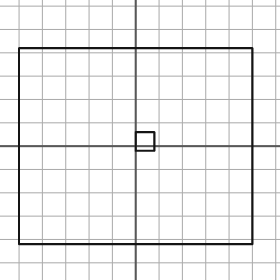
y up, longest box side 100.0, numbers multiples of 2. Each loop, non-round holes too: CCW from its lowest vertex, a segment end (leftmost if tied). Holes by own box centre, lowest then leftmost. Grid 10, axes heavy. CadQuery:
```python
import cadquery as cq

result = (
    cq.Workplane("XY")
    .moveTo(-50.0, -42.0)
    .lineTo(50.0, -42.0)
    .lineTo(50.0, 42.0)
    .lineTo(-50.0, 42.0)
    .close()
    .moveTo(0.0, -2.0)
    .lineTo(8.0, -2.0)
    .lineTo(8.0, 6.0)
    .lineTo(0.0, 6.0)
    .close()
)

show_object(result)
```